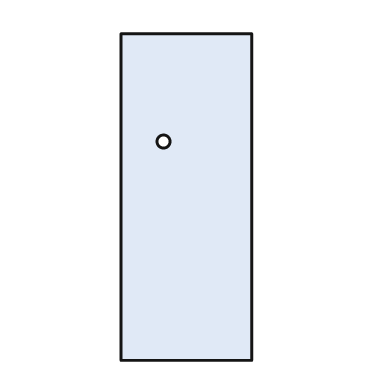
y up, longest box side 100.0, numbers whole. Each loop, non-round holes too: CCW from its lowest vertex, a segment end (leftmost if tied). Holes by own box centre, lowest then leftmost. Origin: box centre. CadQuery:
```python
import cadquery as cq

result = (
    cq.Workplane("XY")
    .moveTo(-20.0, -50.0)
    .lineTo(20.0, -50.0)
    .lineTo(20.0, 50.0)
    .lineTo(-20.0, 50.0)
    .close()
    .moveTo(-7.0, 17.0)
    .circle(2.0)
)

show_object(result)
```